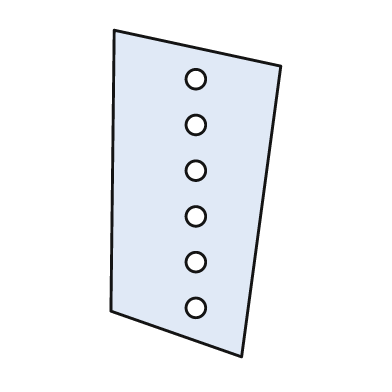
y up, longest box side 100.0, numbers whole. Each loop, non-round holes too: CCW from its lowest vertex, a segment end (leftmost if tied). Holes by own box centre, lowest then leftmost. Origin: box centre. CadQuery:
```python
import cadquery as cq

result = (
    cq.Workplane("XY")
    .moveTo(14.0, -50.0)
    .lineTo(26.0, 39.0)
    .lineTo(-25.0, 50.0)
    .lineTo(-26.0, -36.0)
    .close()
    .moveTo(0.0, -35.0)
    .circle(3.0)
    .moveTo(0.0, -21.0)
    .circle(3.0)
    .moveTo(0.0, -7.0)
    .circle(3.0)
    .moveTo(0.0, 7.0)
    .circle(3.0)
    .moveTo(0.0, 21.0)
    .circle(3.0)
    .moveTo(0.0, 35.0)
    .circle(3.0)
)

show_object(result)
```